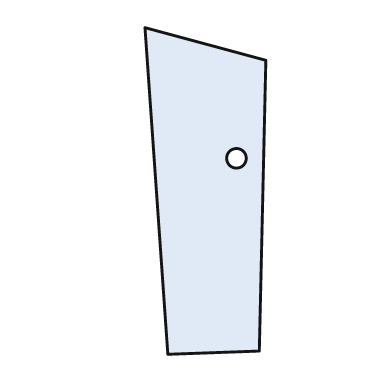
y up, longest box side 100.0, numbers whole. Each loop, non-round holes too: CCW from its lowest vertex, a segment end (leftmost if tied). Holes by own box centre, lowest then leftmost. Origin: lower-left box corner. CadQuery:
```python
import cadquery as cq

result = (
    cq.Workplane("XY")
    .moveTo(7.0, 0.0)
    .lineTo(35.0, 1.0)
    .lineTo(37.0, 90.0)
    .lineTo(0.0, 100.0)
    .close()
    .moveTo(28.0, 60.0)
    .circle(3.0)
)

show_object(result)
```